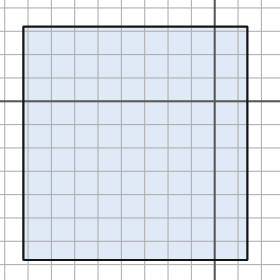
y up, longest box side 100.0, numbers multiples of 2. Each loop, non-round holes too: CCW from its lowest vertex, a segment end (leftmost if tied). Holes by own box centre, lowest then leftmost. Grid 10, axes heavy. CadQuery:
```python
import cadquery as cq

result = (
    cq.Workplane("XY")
    .moveTo(-82.0, -68.0)
    .lineTo(14.0, -68.0)
    .lineTo(14.0, 32.0)
    .lineTo(-82.0, 32.0)
    .close()
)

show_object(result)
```